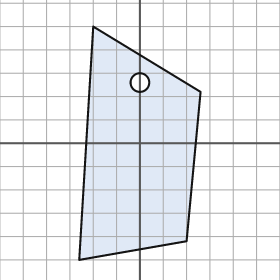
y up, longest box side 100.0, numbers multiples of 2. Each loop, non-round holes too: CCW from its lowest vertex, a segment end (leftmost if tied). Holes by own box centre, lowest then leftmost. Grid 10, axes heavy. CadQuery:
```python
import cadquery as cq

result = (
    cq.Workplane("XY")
    .moveTo(-26.0, -50.0)
    .lineTo(20.0, -42.0)
    .lineTo(26.0, 22.0)
    .lineTo(-20.0, 50.0)
    .close()
    .moveTo(0.0, 26.0)
    .circle(4.0)
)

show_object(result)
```